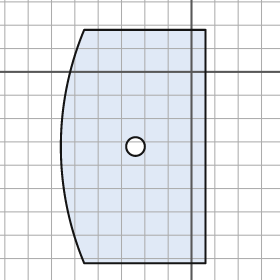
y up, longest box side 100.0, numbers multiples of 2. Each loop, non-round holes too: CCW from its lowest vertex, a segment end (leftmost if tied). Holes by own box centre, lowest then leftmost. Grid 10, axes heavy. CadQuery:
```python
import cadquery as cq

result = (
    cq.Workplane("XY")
    .moveTo(-46.0, -82.0)
    .lineTo(6.0, -82.0)
    .lineTo(6.0, 18.0)
    .lineTo(-46.0, 18.0)
    .threePointArc((-56.0, -32.0), (-46.0, -82.0))
    .close()
    .moveTo(-24.0, -32.0)
    .circle(4.0)
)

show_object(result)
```